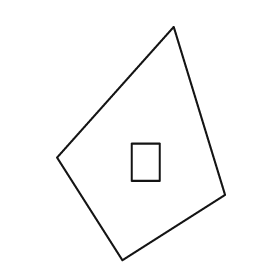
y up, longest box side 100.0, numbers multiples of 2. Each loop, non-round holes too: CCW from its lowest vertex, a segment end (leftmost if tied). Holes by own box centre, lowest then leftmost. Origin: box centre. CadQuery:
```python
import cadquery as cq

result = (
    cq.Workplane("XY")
    .moveTo(-8.0, -50.0)
    .lineTo(36.0, -22.0)
    .lineTo(14.0, 50.0)
    .lineTo(-36.0, -6.0)
    .close()
    .moveTo(-4.0, -16.0)
    .lineTo(8.0, -16.0)
    .lineTo(8.0, 0.0)
    .lineTo(-4.0, 0.0)
    .close()
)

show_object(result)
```